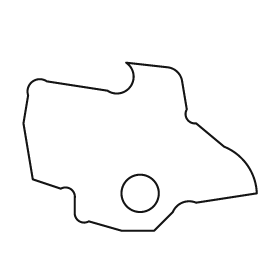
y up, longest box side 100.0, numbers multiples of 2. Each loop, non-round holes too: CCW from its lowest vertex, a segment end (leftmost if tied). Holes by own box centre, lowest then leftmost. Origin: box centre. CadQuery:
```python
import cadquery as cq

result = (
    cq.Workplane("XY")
    .moveTo(-8.0, -36.0)
    .lineTo(6.0, -36.0)
    .lineTo(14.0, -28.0)
    .threePointArc((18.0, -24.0), (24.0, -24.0))
    .lineTo(50.0, -20.0)
    .threePointArc((46.0, -8.0), (36.0, 0.0))
    .lineTo(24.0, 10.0)
    .threePointArc((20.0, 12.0), (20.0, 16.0))
    .lineTo(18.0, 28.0)
    .threePointArc((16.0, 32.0), (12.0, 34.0))
    .lineTo(-6.0, 36.0)
    .threePointArc((-4.0, 26.0), (-14.0, 24.0))
    .lineTo(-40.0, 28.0)
    .threePointArc((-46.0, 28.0), (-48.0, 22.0))
    .lineTo(-50.0, 10.0)
    .lineTo(-46.0, -14.0)
    .lineTo(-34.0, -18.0)
    .threePointArc((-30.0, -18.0), (-28.0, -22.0))
    .lineTo(-28.0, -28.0)
    .threePointArc((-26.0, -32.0), (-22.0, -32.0))
    .close()
    .moveTo(0.0, -20.0)
    .circle(8.0)
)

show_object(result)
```